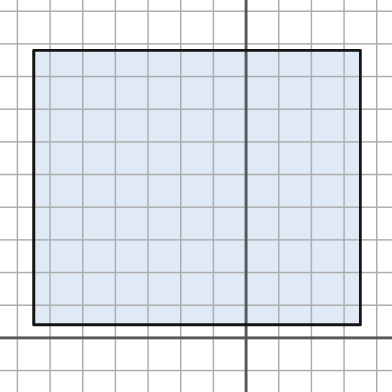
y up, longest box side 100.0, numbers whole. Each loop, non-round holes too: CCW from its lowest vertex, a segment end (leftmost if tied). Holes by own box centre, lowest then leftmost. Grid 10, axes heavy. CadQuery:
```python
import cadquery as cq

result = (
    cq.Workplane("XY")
    .moveTo(-65.0, 4.0)
    .lineTo(35.0, 4.0)
    .lineTo(35.0, 88.0)
    .lineTo(-65.0, 88.0)
    .close()
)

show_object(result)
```